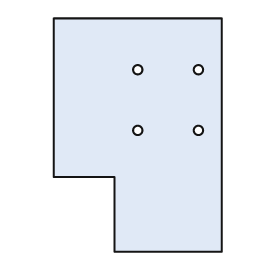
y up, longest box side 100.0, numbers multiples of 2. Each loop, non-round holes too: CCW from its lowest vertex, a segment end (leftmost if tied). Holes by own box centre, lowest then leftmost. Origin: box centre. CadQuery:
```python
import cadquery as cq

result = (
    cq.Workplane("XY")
    .moveTo(-10.0, -50.0)
    .lineTo(36.0, -50.0)
    .lineTo(36.0, 50.0)
    .lineTo(-36.0, 50.0)
    .lineTo(-36.0, -18.0)
    .lineTo(-10.0, -18.0)
    .close()
    .moveTo(0.0, 2.0)
    .circle(2.0)
    .moveTo(26.0, 2.0)
    .circle(2.0)
    .moveTo(0.0, 28.0)
    .circle(2.0)
    .moveTo(26.0, 28.0)
    .circle(2.0)
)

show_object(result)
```